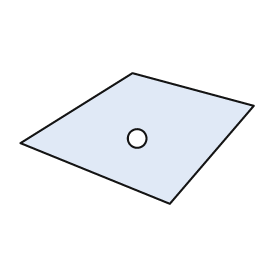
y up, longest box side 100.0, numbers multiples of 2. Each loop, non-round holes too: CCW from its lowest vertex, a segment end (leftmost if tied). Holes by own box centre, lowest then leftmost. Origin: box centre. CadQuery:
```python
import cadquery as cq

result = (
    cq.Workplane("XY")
    .moveTo(14.0, -28.0)
    .lineTo(50.0, 14.0)
    .lineTo(-2.0, 28.0)
    .lineTo(-50.0, -2.0)
    .close()
    .moveTo(0.0, 0.0)
    .circle(4.0)
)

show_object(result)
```